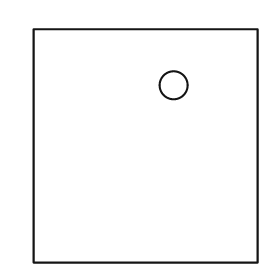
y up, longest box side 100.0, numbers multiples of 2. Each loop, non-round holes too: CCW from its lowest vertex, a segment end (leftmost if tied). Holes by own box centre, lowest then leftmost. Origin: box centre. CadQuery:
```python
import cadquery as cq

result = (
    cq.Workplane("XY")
    .moveTo(-48.0, -50.0)
    .lineTo(48.0, -50.0)
    .lineTo(48.0, 50.0)
    .lineTo(-48.0, 50.0)
    .close()
    .moveTo(12.0, 26.0)
    .circle(6.0)
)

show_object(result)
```